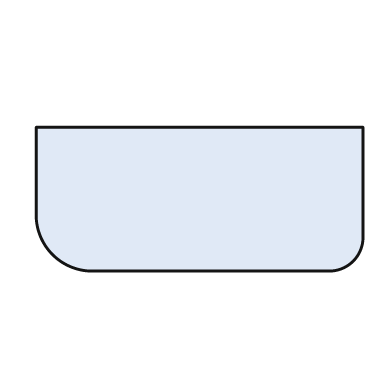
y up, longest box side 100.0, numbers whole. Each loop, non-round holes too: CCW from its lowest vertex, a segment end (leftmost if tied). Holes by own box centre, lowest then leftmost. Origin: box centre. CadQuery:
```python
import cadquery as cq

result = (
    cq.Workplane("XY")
    .moveTo(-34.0, -22.0)
    .lineTo(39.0, -22.0)
    .threePointArc((47.0, -19.0), (50.0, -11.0))
    .lineTo(50.0, 22.0)
    .lineTo(-50.0, 22.0)
    .lineTo(-50.0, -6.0)
    .threePointArc((-45.0, -17.0), (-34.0, -22.0))
    .close()
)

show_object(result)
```